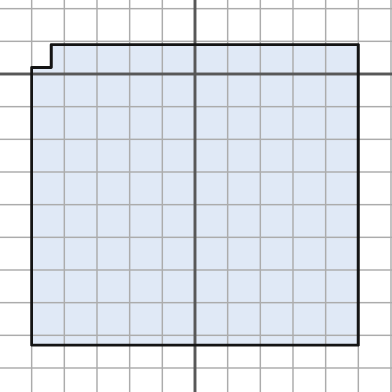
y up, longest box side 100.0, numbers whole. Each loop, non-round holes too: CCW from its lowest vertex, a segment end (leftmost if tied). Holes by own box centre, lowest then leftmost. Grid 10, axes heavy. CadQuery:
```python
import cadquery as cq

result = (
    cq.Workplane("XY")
    .moveTo(-50.0, -83.0)
    .lineTo(50.0, -83.0)
    .lineTo(50.0, 9.0)
    .lineTo(-44.0, 9.0)
    .lineTo(-44.0, 2.0)
    .lineTo(-50.0, 2.0)
    .close()
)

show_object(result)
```